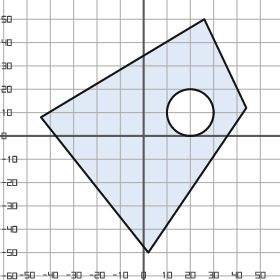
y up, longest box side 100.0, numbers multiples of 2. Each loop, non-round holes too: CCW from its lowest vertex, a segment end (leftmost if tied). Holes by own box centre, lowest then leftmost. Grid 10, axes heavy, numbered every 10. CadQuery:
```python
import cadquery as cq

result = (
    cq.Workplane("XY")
    .moveTo(2.0, -50.0)
    .lineTo(44.0, 12.0)
    .lineTo(26.0, 50.0)
    .lineTo(-44.0, 8.0)
    .close()
    .moveTo(20.0, 10.0)
    .circle(10.0)
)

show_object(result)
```